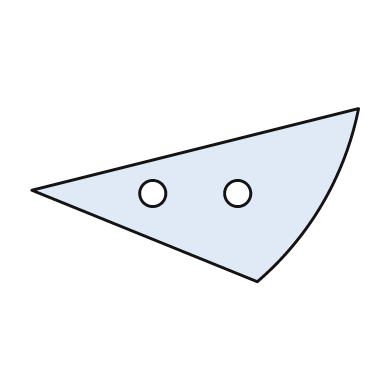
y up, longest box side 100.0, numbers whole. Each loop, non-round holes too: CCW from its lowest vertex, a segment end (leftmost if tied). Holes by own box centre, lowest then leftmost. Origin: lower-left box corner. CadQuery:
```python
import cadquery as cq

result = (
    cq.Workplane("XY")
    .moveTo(69.0, 0.0)
    .threePointArc((89.0, 24.0), (100.0, 53.0))
    .lineTo(0.0, 28.0)
    .close()
    .moveTo(37.0, 27.0)
    .circle(4.0)
    .moveTo(63.0, 27.0)
    .circle(4.0)
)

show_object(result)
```